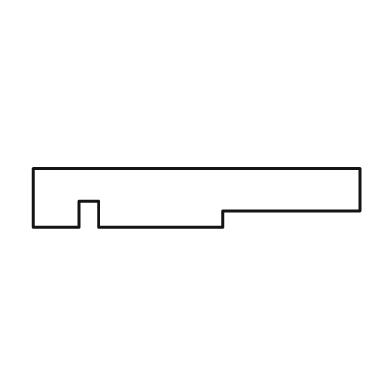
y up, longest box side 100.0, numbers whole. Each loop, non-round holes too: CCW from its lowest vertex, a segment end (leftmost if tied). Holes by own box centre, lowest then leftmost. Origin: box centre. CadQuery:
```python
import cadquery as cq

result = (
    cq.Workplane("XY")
    .moveTo(-50.0, -9.0)
    .lineTo(-36.0, -9.0)
    .lineTo(-36.0, -1.0)
    .lineTo(-30.0, -1.0)
    .lineTo(-30.0, -9.0)
    .lineTo(8.0, -9.0)
    .lineTo(8.0, -4.0)
    .lineTo(50.0, -4.0)
    .lineTo(50.0, 9.0)
    .lineTo(-50.0, 9.0)
    .close()
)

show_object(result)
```